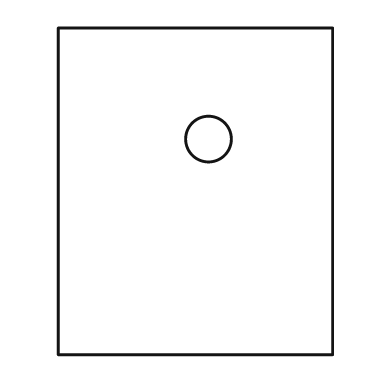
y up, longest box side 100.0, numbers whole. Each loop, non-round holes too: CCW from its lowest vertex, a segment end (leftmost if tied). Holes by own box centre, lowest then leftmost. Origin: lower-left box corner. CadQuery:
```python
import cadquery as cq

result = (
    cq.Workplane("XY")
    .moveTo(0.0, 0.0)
    .lineTo(84.0, 0.0)
    .lineTo(84.0, 100.0)
    .lineTo(0.0, 100.0)
    .close()
    .moveTo(46.0, 66.0)
    .circle(7.0)
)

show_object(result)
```